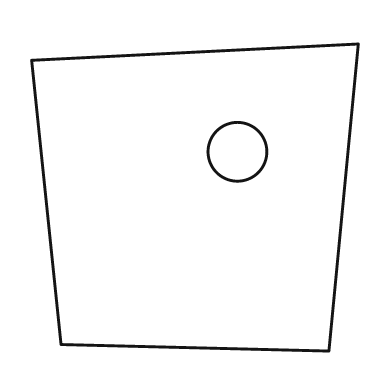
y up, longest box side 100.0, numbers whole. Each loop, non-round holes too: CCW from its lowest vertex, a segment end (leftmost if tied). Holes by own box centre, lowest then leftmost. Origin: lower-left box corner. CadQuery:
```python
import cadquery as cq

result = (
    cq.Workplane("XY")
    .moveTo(91.0, 0.0)
    .lineTo(100.0, 94.0)
    .lineTo(0.0, 89.0)
    .lineTo(9.0, 2.0)
    .close()
    .moveTo(63.0, 61.0)
    .circle(9.0)
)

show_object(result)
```